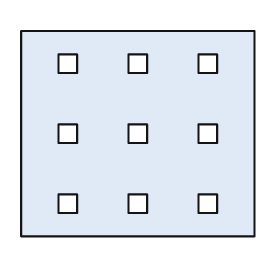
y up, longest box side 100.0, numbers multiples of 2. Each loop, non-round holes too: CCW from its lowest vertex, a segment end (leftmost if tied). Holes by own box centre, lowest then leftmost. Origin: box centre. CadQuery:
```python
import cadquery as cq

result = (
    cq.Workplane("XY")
    .moveTo(-50.0, -44.0)
    .lineTo(50.0, -44.0)
    .lineTo(50.0, 44.0)
    .lineTo(-50.0, 44.0)
    .close()
    .moveTo(-34.0, -34.0)
    .lineTo(-26.0, -34.0)
    .lineTo(-26.0, -26.0)
    .lineTo(-34.0, -26.0)
    .close()
    .moveTo(-4.0, -34.0)
    .lineTo(4.0, -34.0)
    .lineTo(4.0, -26.0)
    .lineTo(-4.0, -26.0)
    .close()
    .moveTo(26.0, -34.0)
    .lineTo(34.0, -34.0)
    .lineTo(34.0, -26.0)
    .lineTo(26.0, -26.0)
    .close()
    .moveTo(-34.0, -4.0)
    .lineTo(-26.0, -4.0)
    .lineTo(-26.0, 4.0)
    .lineTo(-34.0, 4.0)
    .close()
    .moveTo(-4.0, -4.0)
    .lineTo(4.0, -4.0)
    .lineTo(4.0, 4.0)
    .lineTo(-4.0, 4.0)
    .close()
    .moveTo(26.0, -4.0)
    .lineTo(34.0, -4.0)
    .lineTo(34.0, 4.0)
    .lineTo(26.0, 4.0)
    .close()
    .moveTo(-34.0, 26.0)
    .lineTo(-26.0, 26.0)
    .lineTo(-26.0, 34.0)
    .lineTo(-34.0, 34.0)
    .close()
    .moveTo(-4.0, 26.0)
    .lineTo(4.0, 26.0)
    .lineTo(4.0, 34.0)
    .lineTo(-4.0, 34.0)
    .close()
    .moveTo(26.0, 26.0)
    .lineTo(34.0, 26.0)
    .lineTo(34.0, 34.0)
    .lineTo(26.0, 34.0)
    .close()
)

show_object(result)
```